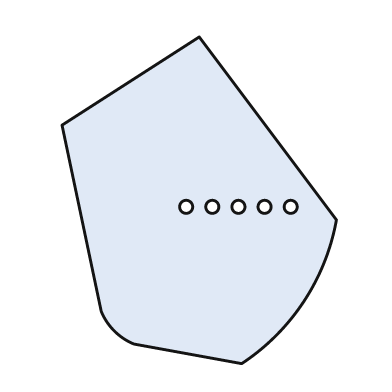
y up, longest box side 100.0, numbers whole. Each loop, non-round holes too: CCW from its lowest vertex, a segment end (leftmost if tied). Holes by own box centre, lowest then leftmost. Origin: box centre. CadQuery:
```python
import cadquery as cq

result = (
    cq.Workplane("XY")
    .moveTo(13.0, -50.0)
    .threePointArc((32.0, -31.0), (42.0, -6.0))
    .lineTo(0.0, 50.0)
    .lineTo(-42.0, 23.0)
    .lineTo(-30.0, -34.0)
    .threePointArc((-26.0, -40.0), (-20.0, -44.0))
    .close()
    .moveTo(-4.0, -2.0)
    .circle(2.0)
    .moveTo(4.0, -2.0)
    .circle(2.0)
    .moveTo(12.0, -2.0)
    .circle(2.0)
    .moveTo(20.0, -2.0)
    .circle(2.0)
    .moveTo(28.0, -2.0)
    .circle(2.0)
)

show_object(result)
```